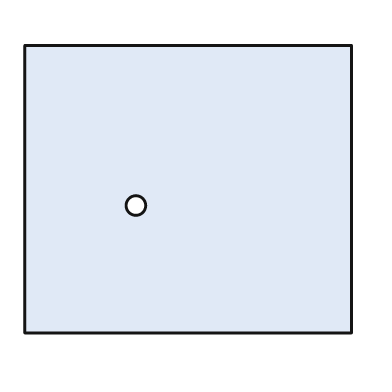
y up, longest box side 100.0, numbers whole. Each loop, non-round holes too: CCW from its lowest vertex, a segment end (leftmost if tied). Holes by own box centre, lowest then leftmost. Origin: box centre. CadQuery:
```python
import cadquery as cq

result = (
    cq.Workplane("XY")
    .moveTo(-50.0, -44.0)
    .lineTo(50.0, -44.0)
    .lineTo(50.0, 44.0)
    .lineTo(-50.0, 44.0)
    .close()
    .moveTo(-16.0, -5.0)
    .circle(3.0)
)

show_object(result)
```